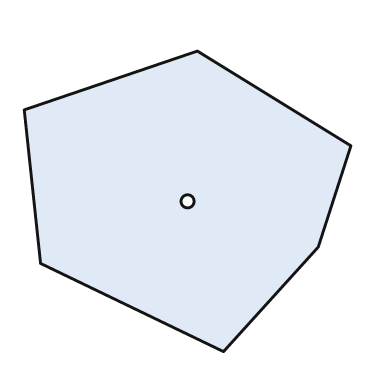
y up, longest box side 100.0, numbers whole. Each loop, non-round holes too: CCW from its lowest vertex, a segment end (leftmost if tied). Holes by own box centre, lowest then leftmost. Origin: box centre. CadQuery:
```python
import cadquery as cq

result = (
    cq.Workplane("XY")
    .moveTo(11.0, -46.0)
    .lineTo(40.0, -14.0)
    .lineTo(50.0, 17.0)
    .lineTo(3.0, 46.0)
    .lineTo(-50.0, 28.0)
    .lineTo(-45.0, -19.0)
    .close()
    .moveTo(0.0, 0.0)
    .circle(2.0)
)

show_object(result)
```